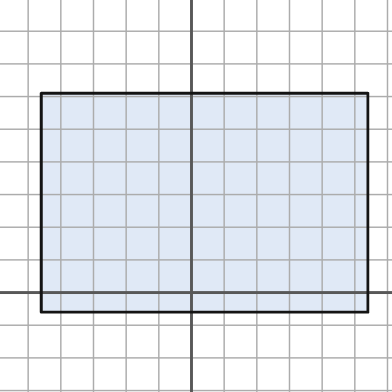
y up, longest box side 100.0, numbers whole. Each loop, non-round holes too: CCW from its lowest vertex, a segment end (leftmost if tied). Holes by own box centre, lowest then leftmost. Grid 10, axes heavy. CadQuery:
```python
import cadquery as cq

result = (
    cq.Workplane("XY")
    .moveTo(-46.0, -6.0)
    .lineTo(54.0, -6.0)
    .lineTo(54.0, 61.0)
    .lineTo(-46.0, 61.0)
    .close()
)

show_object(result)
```